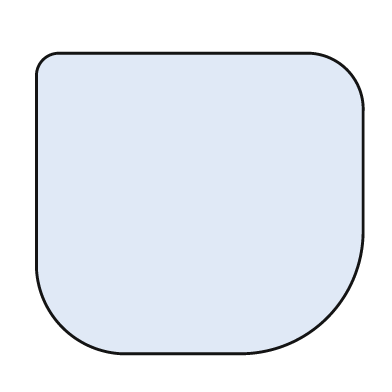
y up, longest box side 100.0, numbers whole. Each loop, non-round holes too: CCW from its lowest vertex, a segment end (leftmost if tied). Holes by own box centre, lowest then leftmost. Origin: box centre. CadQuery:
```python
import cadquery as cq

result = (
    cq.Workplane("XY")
    .moveTo(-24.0, -46.0)
    .lineTo(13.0, -46.0)
    .threePointArc((39.0, -35.0), (50.0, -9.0))
    .lineTo(50.0, 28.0)
    .threePointArc((45.0, 41.0), (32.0, 46.0))
    .lineTo(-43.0, 46.0)
    .threePointArc((-48.0, 44.0), (-50.0, 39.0))
    .lineTo(-50.0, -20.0)
    .threePointArc((-42.0, -38.0), (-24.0, -46.0))
    .close()
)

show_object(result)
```